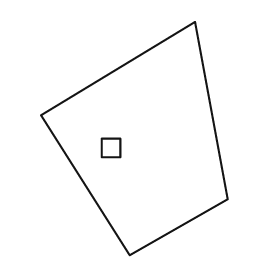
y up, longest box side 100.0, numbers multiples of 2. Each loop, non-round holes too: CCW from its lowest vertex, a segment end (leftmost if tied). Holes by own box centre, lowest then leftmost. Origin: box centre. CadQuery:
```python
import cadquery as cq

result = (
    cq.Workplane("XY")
    .moveTo(-2.0, -50.0)
    .lineTo(40.0, -26.0)
    .lineTo(26.0, 50.0)
    .lineTo(-40.0, 10.0)
    .close()
    .moveTo(-14.0, -8.0)
    .lineTo(-6.0, -8.0)
    .lineTo(-6.0, 0.0)
    .lineTo(-14.0, 0.0)
    .close()
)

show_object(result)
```